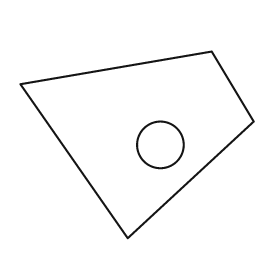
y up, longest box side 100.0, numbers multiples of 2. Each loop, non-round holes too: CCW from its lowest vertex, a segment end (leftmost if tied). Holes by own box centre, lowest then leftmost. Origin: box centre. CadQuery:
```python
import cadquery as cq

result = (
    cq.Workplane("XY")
    .moveTo(-4.0, -40.0)
    .lineTo(50.0, 10.0)
    .lineTo(32.0, 40.0)
    .lineTo(-50.0, 26.0)
    .close()
    .moveTo(10.0, 0.0)
    .circle(10.0)
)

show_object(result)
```